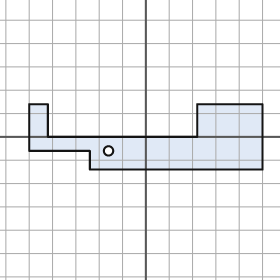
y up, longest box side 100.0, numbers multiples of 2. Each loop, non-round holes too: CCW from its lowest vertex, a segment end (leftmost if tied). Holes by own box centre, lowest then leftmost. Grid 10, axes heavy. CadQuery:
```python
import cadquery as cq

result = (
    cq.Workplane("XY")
    .moveTo(-24.0, -14.0)
    .lineTo(50.0, -14.0)
    .lineTo(50.0, 14.0)
    .lineTo(22.0, 14.0)
    .lineTo(22.0, 0.0)
    .lineTo(-42.0, 0.0)
    .lineTo(-42.0, 14.0)
    .lineTo(-50.0, 14.0)
    .lineTo(-50.0, -6.0)
    .lineTo(-24.0, -6.0)
    .close()
    .moveTo(-16.0, -6.0)
    .circle(2.0)
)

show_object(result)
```